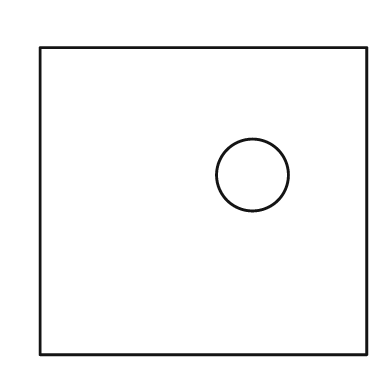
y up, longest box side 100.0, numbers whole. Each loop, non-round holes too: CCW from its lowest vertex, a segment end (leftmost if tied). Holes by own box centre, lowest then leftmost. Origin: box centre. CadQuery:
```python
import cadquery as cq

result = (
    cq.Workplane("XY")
    .moveTo(-50.0, -47.0)
    .lineTo(50.0, -47.0)
    .lineTo(50.0, 47.0)
    .lineTo(-50.0, 47.0)
    .close()
    .moveTo(15.0, 8.0)
    .circle(11.0)
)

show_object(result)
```